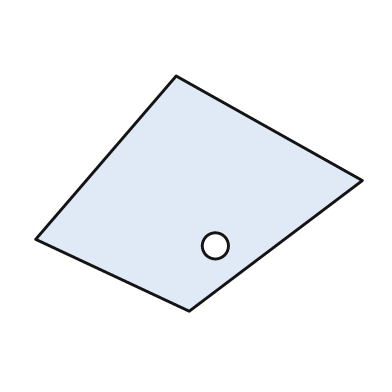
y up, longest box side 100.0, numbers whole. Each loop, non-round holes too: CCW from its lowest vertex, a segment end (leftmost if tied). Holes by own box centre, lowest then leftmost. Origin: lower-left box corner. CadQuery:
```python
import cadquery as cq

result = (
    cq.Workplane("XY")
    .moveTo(47.0, 0.0)
    .lineTo(100.0, 40.0)
    .lineTo(43.0, 72.0)
    .lineTo(0.0, 22.0)
    .close()
    .moveTo(55.0, 20.0)
    .circle(4.0)
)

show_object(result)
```